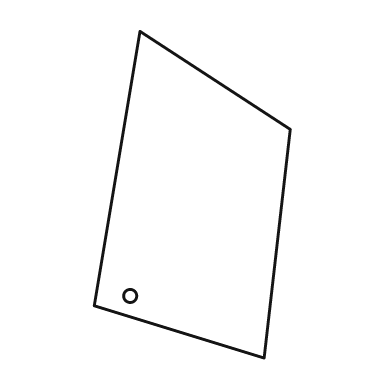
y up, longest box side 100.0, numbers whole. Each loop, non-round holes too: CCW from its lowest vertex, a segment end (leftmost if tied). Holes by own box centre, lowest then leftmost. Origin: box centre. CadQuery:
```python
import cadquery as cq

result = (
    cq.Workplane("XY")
    .moveTo(22.0, -50.0)
    .lineTo(30.0, 20.0)
    .lineTo(-16.0, 50.0)
    .lineTo(-30.0, -34.0)
    .close()
    .moveTo(-19.0, -31.0)
    .circle(2.0)
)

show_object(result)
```